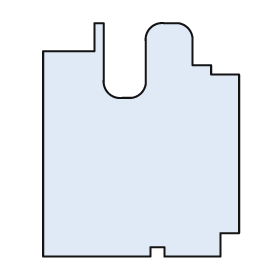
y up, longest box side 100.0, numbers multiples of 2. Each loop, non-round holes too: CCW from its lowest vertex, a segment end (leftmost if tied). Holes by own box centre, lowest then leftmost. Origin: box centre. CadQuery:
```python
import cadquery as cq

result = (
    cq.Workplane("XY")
    .moveTo(-42.0, -50.0)
    .lineTo(4.0, -50.0)
    .lineTo(4.0, -46.0)
    .lineTo(10.0, -46.0)
    .lineTo(10.0, -50.0)
    .lineTo(34.0, -50.0)
    .lineTo(34.0, -40.0)
    .lineTo(42.0, -40.0)
    .lineTo(42.0, 28.0)
    .lineTo(30.0, 28.0)
    .lineTo(30.0, 32.0)
    .lineTo(22.0, 32.0)
    .lineTo(22.0, 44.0)
    .threePointArc((20.0, 48.0), (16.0, 50.0))
    .lineTo(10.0, 50.0)
    .threePointArc((4.0, 48.0), (2.0, 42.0))
    .lineTo(2.0, 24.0)
    .threePointArc((0.0, 20.0), (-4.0, 18.0))
    .lineTo(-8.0, 18.0)
    .threePointArc((-14.0, 20.0), (-16.0, 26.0))
    .lineTo(-16.0, 50.0)
    .lineTo(-20.0, 50.0)
    .lineTo(-20.0, 38.0)
    .lineTo(-42.0, 38.0)
    .close()
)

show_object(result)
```